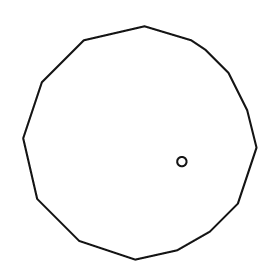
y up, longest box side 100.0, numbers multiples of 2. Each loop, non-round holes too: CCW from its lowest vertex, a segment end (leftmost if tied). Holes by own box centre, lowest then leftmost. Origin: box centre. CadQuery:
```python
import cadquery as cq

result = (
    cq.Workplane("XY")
    .moveTo(-2.0, -50.0)
    .lineTo(16.0, -46.0)
    .lineTo(30.0, -38.0)
    .lineTo(42.0, -26.0)
    .lineTo(50.0, -2.0)
    .lineTo(46.0, 14.0)
    .lineTo(38.0, 30.0)
    .lineTo(28.0, 40.0)
    .lineTo(22.0, 44.0)
    .lineTo(2.0, 50.0)
    .lineTo(-24.0, 44.0)
    .lineTo(-42.0, 26.0)
    .lineTo(-50.0, 2.0)
    .lineTo(-44.0, -24.0)
    .lineTo(-26.0, -42.0)
    .close()
    .moveTo(18.0, -8.0)
    .circle(2.0)
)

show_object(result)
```